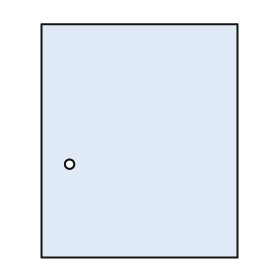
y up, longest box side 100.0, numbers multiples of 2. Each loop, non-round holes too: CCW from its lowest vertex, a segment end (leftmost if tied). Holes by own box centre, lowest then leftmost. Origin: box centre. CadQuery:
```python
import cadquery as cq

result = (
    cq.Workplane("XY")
    .moveTo(-42.0, -50.0)
    .lineTo(42.0, -50.0)
    .lineTo(42.0, 50.0)
    .lineTo(-42.0, 50.0)
    .close()
    .moveTo(-30.0, -10.0)
    .circle(2.0)
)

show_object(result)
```